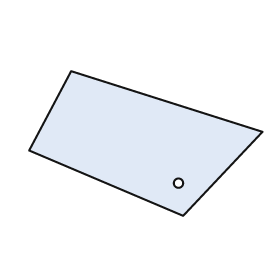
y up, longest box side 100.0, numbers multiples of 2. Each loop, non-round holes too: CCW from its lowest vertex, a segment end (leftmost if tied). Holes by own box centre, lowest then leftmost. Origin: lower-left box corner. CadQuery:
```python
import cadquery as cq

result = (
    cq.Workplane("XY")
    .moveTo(66.0, 0.0)
    .lineTo(100.0, 36.0)
    .lineTo(18.0, 62.0)
    .lineTo(0.0, 28.0)
    .close()
    .moveTo(64.0, 14.0)
    .circle(2.0)
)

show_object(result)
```